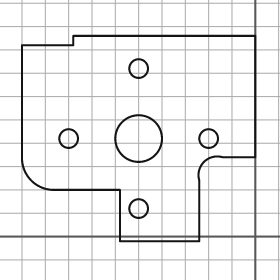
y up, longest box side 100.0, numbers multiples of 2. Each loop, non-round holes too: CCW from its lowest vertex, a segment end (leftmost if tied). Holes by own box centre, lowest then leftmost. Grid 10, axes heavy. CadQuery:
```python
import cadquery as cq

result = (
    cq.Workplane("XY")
    .moveTo(-58.0, -2.0)
    .lineTo(-24.0, -2.0)
    .lineTo(-24.0, 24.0)
    .threePointArc((-22.0, 32.0), (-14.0, 34.0))
    .lineTo(0.0, 34.0)
    .lineTo(0.0, 86.0)
    .lineTo(-78.0, 86.0)
    .lineTo(-78.0, 82.0)
    .lineTo(-100.0, 82.0)
    .lineTo(-100.0, 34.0)
    .threePointArc((-96.0, 24.0), (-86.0, 20.0))
    .lineTo(-58.0, 20.0)
    .close()
    .moveTo(-50.0, 12.0)
    .circle(4.0)
    .moveTo(-80.0, 42.0)
    .circle(4.0)
    .moveTo(-50.0, 42.0)
    .circle(10.0)
    .moveTo(-20.0, 42.0)
    .circle(4.0)
    .moveTo(-50.0, 72.0)
    .circle(4.0)
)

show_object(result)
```